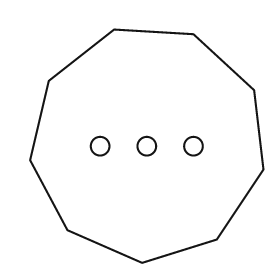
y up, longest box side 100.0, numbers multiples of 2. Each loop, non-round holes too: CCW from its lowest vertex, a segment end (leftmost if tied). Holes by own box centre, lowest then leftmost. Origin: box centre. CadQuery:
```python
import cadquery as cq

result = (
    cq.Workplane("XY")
    .moveTo(-2.0, -50.0)
    .lineTo(30.0, -40.0)
    .lineTo(50.0, -10.0)
    .lineTo(46.0, 24.0)
    .lineTo(20.0, 48.0)
    .lineTo(-14.0, 50.0)
    .lineTo(-42.0, 28.0)
    .lineTo(-50.0, -6.0)
    .lineTo(-34.0, -36.0)
    .close()
    .moveTo(-20.0, 0.0)
    .circle(4.0)
    .moveTo(0.0, 0.0)
    .circle(4.0)
    .moveTo(20.0, 0.0)
    .circle(4.0)
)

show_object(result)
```